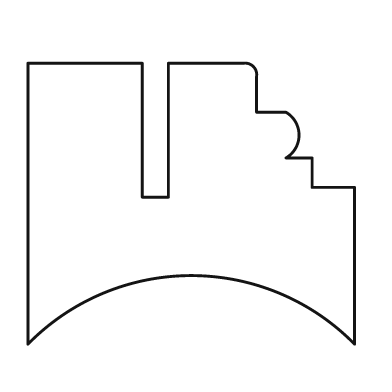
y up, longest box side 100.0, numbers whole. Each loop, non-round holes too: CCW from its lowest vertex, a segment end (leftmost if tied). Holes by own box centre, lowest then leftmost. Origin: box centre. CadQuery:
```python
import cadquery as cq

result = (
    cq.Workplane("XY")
    .moveTo(-50.0, -43.0)
    .threePointArc((0.0, -22.0), (50.0, -43.0))
    .lineTo(50.0, 5.0)
    .lineTo(37.0, 5.0)
    .lineTo(37.0, 14.0)
    .lineTo(29.0, 14.0)
    .threePointArc((33.0, 21.0), (29.0, 28.0))
    .lineTo(20.0, 28.0)
    .lineTo(20.0, 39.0)
    .threePointArc((19.0, 42.0), (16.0, 43.0))
    .lineTo(-7.0, 43.0)
    .lineTo(-7.0, 2.0)
    .lineTo(-15.0, 2.0)
    .lineTo(-15.0, 43.0)
    .lineTo(-50.0, 43.0)
    .close()
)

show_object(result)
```